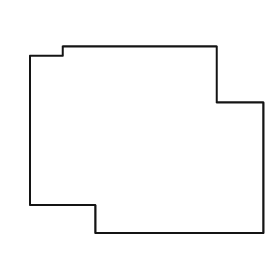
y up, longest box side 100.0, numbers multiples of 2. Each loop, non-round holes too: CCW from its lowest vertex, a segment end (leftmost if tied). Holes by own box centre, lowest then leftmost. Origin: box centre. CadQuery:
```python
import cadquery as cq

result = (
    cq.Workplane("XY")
    .moveTo(-22.0, -40.0)
    .lineTo(50.0, -40.0)
    .lineTo(50.0, 16.0)
    .lineTo(30.0, 16.0)
    .lineTo(30.0, 40.0)
    .lineTo(-36.0, 40.0)
    .lineTo(-36.0, 36.0)
    .lineTo(-50.0, 36.0)
    .lineTo(-50.0, -28.0)
    .lineTo(-22.0, -28.0)
    .close()
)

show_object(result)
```